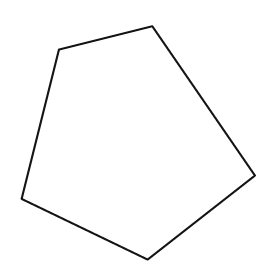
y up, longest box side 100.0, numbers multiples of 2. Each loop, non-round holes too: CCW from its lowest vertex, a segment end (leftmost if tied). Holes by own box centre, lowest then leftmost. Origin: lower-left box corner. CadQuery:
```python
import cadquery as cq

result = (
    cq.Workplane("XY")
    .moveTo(54.0, 0.0)
    .lineTo(100.0, 36.0)
    .lineTo(56.0, 100.0)
    .lineTo(16.0, 90.0)
    .lineTo(0.0, 26.0)
    .close()
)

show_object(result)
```